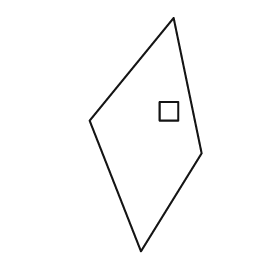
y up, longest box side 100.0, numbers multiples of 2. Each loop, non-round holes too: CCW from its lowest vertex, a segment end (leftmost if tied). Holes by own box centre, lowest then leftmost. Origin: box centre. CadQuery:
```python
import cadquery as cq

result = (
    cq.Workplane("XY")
    .moveTo(-2.0, -50.0)
    .lineTo(24.0, -8.0)
    .lineTo(12.0, 50.0)
    .lineTo(-24.0, 6.0)
    .close()
    .moveTo(6.0, 6.0)
    .lineTo(14.0, 6.0)
    .lineTo(14.0, 14.0)
    .lineTo(6.0, 14.0)
    .close()
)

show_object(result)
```